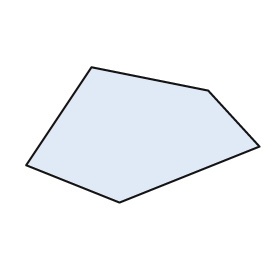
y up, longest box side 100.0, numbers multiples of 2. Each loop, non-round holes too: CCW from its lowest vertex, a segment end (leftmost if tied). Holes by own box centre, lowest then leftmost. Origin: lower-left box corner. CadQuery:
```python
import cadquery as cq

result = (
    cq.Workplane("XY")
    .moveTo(40.0, 0.0)
    .lineTo(100.0, 24.0)
    .lineTo(78.0, 48.0)
    .lineTo(28.0, 58.0)
    .lineTo(0.0, 16.0)
    .close()
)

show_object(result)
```